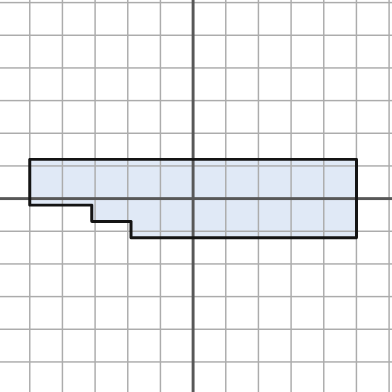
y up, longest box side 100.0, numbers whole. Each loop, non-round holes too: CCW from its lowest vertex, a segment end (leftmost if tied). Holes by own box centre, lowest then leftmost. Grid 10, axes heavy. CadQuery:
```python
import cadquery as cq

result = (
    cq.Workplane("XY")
    .moveTo(-19.0, -12.0)
    .lineTo(50.0, -12.0)
    .lineTo(50.0, 12.0)
    .lineTo(-50.0, 12.0)
    .lineTo(-50.0, -2.0)
    .lineTo(-31.0, -2.0)
    .lineTo(-31.0, -7.0)
    .lineTo(-19.0, -7.0)
    .close()
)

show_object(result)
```